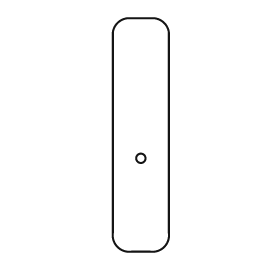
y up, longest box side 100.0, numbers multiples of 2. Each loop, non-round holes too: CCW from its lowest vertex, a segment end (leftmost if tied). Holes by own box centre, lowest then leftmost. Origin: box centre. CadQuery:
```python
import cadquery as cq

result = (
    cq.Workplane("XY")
    .moveTo(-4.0, -50.0)
    .lineTo(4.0, -50.0)
    .threePointArc((10.0, -48.0), (12.0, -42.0))
    .lineTo(12.0, 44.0)
    .threePointArc((10.0, 48.0), (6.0, 50.0))
    .lineTo(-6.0, 50.0)
    .threePointArc((-10.0, 48.0), (-12.0, 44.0))
    .lineTo(-12.0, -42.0)
    .threePointArc((-10.0, -48.0), (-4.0, -50.0))
    .close()
    .moveTo(0.0, -10.0)
    .circle(2.0)
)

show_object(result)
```